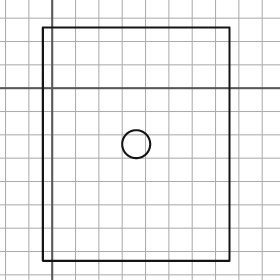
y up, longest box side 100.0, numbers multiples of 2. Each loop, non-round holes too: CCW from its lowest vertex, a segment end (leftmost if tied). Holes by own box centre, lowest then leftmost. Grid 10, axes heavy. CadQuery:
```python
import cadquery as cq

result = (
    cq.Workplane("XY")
    .moveTo(-4.0, -74.0)
    .lineTo(76.0, -74.0)
    .lineTo(76.0, 26.0)
    .lineTo(-4.0, 26.0)
    .close()
    .moveTo(36.0, -24.0)
    .circle(6.0)
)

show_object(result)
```